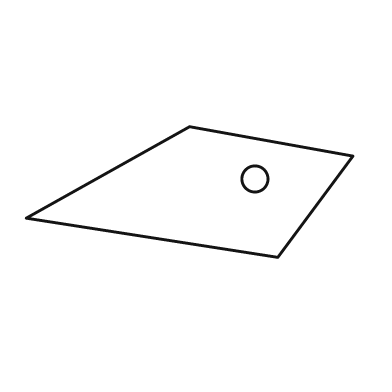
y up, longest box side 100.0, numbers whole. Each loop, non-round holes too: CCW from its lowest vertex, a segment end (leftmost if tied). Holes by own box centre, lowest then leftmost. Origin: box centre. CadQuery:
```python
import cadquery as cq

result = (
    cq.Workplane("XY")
    .moveTo(27.0, -20.0)
    .lineTo(50.0, 11.0)
    .lineTo(0.0, 20.0)
    .lineTo(-50.0, -8.0)
    .close()
    .moveTo(20.0, 4.0)
    .circle(4.0)
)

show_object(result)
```